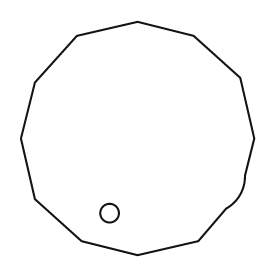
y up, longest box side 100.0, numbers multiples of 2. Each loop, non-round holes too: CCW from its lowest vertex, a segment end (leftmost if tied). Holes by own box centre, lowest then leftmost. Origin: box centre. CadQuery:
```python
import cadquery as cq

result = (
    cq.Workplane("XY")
    .moveTo(0.0, -50.0)
    .lineTo(26.0, -44.0)
    .lineTo(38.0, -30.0)
    .threePointArc((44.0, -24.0), (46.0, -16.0))
    .lineTo(50.0, 0.0)
    .lineTo(44.0, 26.0)
    .lineTo(24.0, 44.0)
    .lineTo(0.0, 50.0)
    .lineTo(-26.0, 44.0)
    .lineTo(-44.0, 24.0)
    .lineTo(-50.0, 0.0)
    .lineTo(-44.0, -26.0)
    .lineTo(-24.0, -44.0)
    .close()
    .moveTo(-12.0, -32.0)
    .circle(4.0)
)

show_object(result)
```